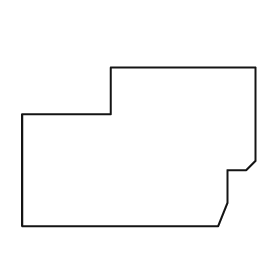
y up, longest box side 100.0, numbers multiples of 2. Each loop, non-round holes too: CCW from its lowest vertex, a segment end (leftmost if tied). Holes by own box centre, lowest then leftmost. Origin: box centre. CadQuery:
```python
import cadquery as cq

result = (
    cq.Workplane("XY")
    .moveTo(-50.0, -34.0)
    .lineTo(34.0, -34.0)
    .lineTo(38.0, -24.0)
    .lineTo(38.0, -10.0)
    .lineTo(46.0, -10.0)
    .lineTo(50.0, -6.0)
    .lineTo(50.0, 34.0)
    .lineTo(-12.0, 34.0)
    .lineTo(-12.0, 14.0)
    .lineTo(-50.0, 14.0)
    .close()
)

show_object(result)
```